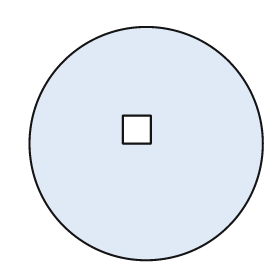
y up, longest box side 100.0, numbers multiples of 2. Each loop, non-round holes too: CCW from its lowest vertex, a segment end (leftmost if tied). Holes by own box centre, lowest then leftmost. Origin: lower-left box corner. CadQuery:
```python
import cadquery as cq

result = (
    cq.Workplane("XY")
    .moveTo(50.0, 50.0)
    .circle(50.0)
    .moveTo(40.0, 50.0)
    .lineTo(52.0, 50.0)
    .lineTo(52.0, 62.0)
    .lineTo(40.0, 62.0)
    .close()
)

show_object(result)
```